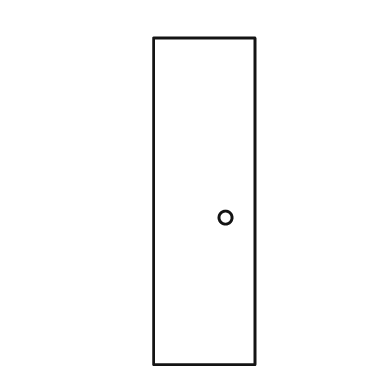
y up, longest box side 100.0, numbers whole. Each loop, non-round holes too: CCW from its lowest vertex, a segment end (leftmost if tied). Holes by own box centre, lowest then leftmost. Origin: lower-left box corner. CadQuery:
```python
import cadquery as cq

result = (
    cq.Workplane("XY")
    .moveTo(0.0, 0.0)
    .lineTo(31.0, 0.0)
    .lineTo(31.0, 100.0)
    .lineTo(0.0, 100.0)
    .close()
    .moveTo(22.0, 45.0)
    .circle(2.0)
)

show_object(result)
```